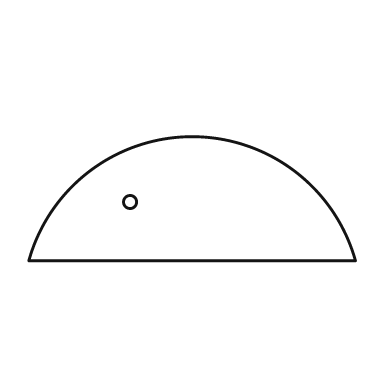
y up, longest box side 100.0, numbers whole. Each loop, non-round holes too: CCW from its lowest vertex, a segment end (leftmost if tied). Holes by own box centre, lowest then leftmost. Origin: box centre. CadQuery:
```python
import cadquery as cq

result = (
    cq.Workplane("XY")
    .moveTo(-50.0, -19.0)
    .lineTo(50.0, -19.0)
    .threePointArc((0.0, 19.0), (-50.0, -19.0))
    .close()
    .moveTo(-19.0, -1.0)
    .circle(2.0)
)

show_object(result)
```